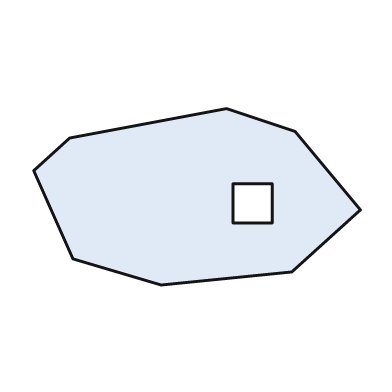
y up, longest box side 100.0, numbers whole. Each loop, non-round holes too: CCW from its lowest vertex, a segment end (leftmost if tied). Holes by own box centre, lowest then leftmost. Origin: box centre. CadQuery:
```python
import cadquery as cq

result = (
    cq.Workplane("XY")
    .moveTo(-11.0, -27.0)
    .lineTo(29.0, -23.0)
    .lineTo(50.0, -4.0)
    .lineTo(30.0, 20.0)
    .lineTo(9.0, 27.0)
    .lineTo(-39.0, 18.0)
    .lineTo(-50.0, 8.0)
    .lineTo(-38.0, -19.0)
    .close()
    .moveTo(11.0, -8.0)
    .lineTo(23.0, -8.0)
    .lineTo(23.0, 4.0)
    .lineTo(11.0, 4.0)
    .close()
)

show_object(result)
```